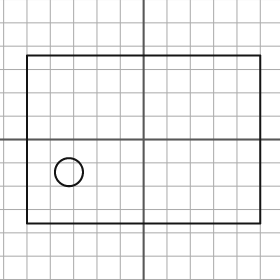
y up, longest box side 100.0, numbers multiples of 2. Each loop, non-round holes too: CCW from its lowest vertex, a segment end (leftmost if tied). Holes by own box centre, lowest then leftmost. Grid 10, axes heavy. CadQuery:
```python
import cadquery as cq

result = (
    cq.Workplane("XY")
    .moveTo(-50.0, -36.0)
    .lineTo(50.0, -36.0)
    .lineTo(50.0, 36.0)
    .lineTo(-50.0, 36.0)
    .close()
    .moveTo(-32.0, -14.0)
    .circle(6.0)
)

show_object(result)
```